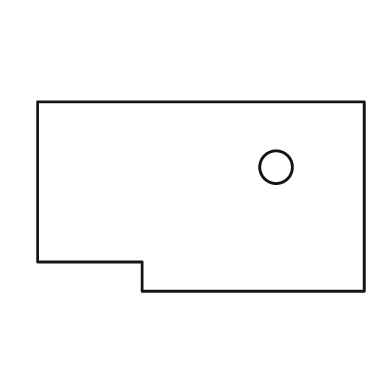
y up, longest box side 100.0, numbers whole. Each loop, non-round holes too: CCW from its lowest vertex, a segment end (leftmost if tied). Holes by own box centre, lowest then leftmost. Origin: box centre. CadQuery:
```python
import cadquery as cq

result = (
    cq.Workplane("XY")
    .moveTo(-18.0, -29.0)
    .lineTo(50.0, -29.0)
    .lineTo(50.0, 29.0)
    .lineTo(-50.0, 29.0)
    .lineTo(-50.0, -20.0)
    .lineTo(-18.0, -20.0)
    .close()
    .moveTo(23.0, 9.0)
    .circle(5.0)
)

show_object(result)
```